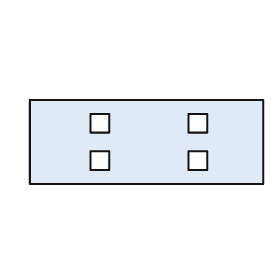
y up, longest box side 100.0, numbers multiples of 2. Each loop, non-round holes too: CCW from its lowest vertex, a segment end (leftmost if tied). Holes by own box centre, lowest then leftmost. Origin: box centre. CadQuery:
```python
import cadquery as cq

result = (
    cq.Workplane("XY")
    .moveTo(-50.0, -18.0)
    .lineTo(50.0, -18.0)
    .lineTo(50.0, 18.0)
    .lineTo(-50.0, 18.0)
    .close()
    .moveTo(-24.0, -12.0)
    .lineTo(-16.0, -12.0)
    .lineTo(-16.0, -4.0)
    .lineTo(-24.0, -4.0)
    .close()
    .moveTo(18.0, -12.0)
    .lineTo(26.0, -12.0)
    .lineTo(26.0, -4.0)
    .lineTo(18.0, -4.0)
    .close()
    .moveTo(-24.0, 4.0)
    .lineTo(-16.0, 4.0)
    .lineTo(-16.0, 12.0)
    .lineTo(-24.0, 12.0)
    .close()
    .moveTo(18.0, 4.0)
    .lineTo(26.0, 4.0)
    .lineTo(26.0, 12.0)
    .lineTo(18.0, 12.0)
    .close()
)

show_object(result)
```